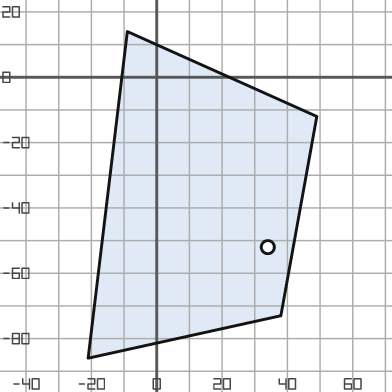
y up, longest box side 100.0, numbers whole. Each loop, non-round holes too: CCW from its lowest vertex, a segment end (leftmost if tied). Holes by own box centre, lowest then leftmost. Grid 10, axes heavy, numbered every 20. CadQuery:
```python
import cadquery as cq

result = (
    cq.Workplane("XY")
    .moveTo(-21.0, -86.0)
    .lineTo(38.0, -73.0)
    .lineTo(49.0, -12.0)
    .lineTo(-9.0, 14.0)
    .close()
    .moveTo(34.0, -52.0)
    .circle(2.0)
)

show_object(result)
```